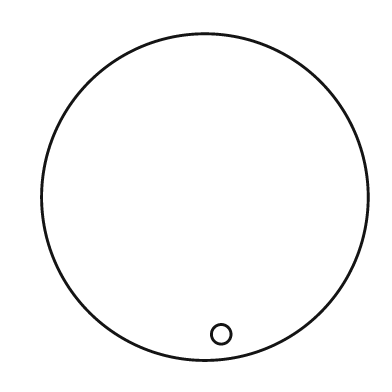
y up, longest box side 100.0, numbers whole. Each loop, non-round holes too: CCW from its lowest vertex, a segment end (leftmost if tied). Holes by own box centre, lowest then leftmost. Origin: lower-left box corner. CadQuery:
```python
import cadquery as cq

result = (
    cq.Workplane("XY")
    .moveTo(50.0, 50.0)
    .circle(50.0)
    .moveTo(55.0, 8.0)
    .circle(3.0)
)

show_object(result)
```